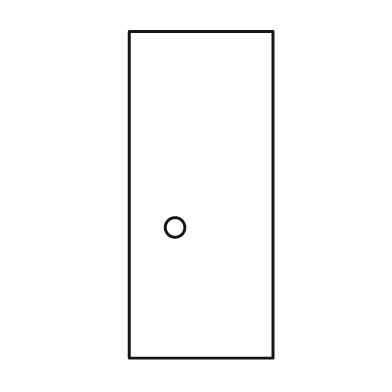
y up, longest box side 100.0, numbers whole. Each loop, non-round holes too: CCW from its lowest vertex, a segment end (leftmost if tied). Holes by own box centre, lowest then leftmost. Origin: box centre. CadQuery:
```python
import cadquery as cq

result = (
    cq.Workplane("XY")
    .moveTo(-22.0, -50.0)
    .lineTo(22.0, -50.0)
    .lineTo(22.0, 50.0)
    .lineTo(-22.0, 50.0)
    .close()
    .moveTo(-8.0, -10.0)
    .circle(3.0)
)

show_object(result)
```